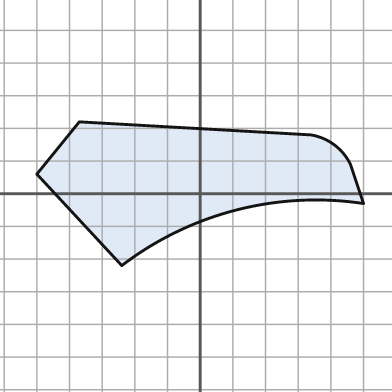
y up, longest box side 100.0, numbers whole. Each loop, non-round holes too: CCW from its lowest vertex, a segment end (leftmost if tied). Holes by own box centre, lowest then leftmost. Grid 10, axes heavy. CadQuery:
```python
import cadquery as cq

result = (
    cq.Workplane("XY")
    .moveTo(-24.0, -22.0)
    .threePointArc((11.0, -5.0), (50.0, -3.0))
    .lineTo(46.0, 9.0)
    .threePointArc((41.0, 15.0), (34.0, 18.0))
    .lineTo(-37.0, 22.0)
    .lineTo(-50.0, 6.0)
    .close()
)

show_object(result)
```